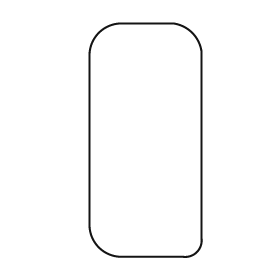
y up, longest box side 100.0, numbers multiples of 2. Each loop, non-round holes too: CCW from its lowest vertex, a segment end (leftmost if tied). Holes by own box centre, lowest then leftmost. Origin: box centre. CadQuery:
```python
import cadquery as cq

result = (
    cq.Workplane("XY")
    .moveTo(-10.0, -50.0)
    .lineTo(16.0, -50.0)
    .threePointArc((22.0, -48.0), (24.0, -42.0))
    .lineTo(24.0, 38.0)
    .threePointArc((20.0, 46.0), (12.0, 50.0))
    .lineTo(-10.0, 50.0)
    .threePointArc((-20.0, 46.0), (-24.0, 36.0))
    .lineTo(-24.0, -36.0)
    .threePointArc((-20.0, -46.0), (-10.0, -50.0))
    .close()
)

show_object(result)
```